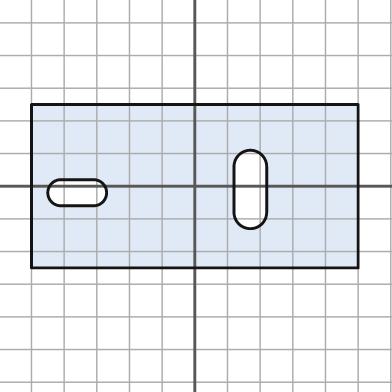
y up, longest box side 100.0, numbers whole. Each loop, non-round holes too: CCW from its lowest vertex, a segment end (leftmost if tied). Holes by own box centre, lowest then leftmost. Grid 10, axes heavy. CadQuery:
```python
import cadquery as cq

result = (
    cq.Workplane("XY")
    .moveTo(-50.0, -25.0)
    .lineTo(50.0, -25.0)
    .lineTo(50.0, 25.0)
    .lineTo(-50.0, 25.0)
    .close()
    .moveTo(-41.0, -6.0)
    .lineTo(-31.0, -6.0)
    .threePointArc((-27.0, -2.0), (-31.0, 2.0))
    .lineTo(-41.0, 2.0)
    .threePointArc((-45.0, -2.0), (-41.0, -6.0))
    .close()
    .moveTo(12.0, -8.0)
    .threePointArc((17.0, -13.0), (22.0, -8.0))
    .lineTo(22.0, 6.0)
    .threePointArc((17.0, 11.0), (12.0, 6.0))
    .close()
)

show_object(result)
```